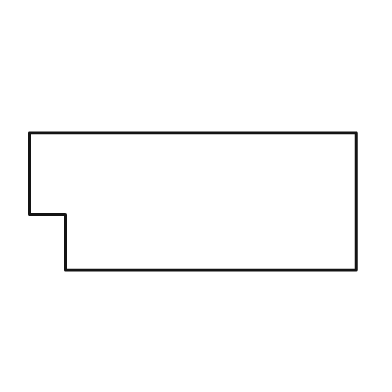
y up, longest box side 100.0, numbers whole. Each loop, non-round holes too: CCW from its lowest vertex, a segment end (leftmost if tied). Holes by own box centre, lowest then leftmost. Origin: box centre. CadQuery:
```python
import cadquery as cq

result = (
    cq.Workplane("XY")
    .moveTo(-39.0, -21.0)
    .lineTo(50.0, -21.0)
    .lineTo(50.0, 21.0)
    .lineTo(-50.0, 21.0)
    .lineTo(-50.0, -4.0)
    .lineTo(-39.0, -4.0)
    .close()
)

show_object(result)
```